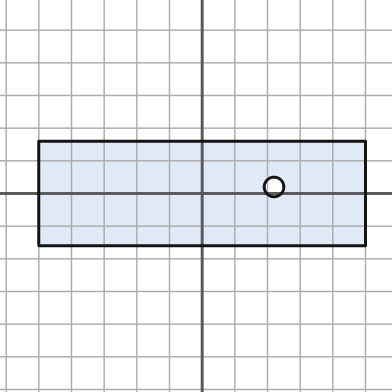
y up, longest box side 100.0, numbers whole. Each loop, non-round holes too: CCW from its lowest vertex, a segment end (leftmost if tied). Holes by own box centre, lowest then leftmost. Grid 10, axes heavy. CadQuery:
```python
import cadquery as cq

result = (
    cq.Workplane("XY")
    .moveTo(-50.0, -16.0)
    .lineTo(50.0, -16.0)
    .lineTo(50.0, 16.0)
    .lineTo(-50.0, 16.0)
    .close()
    .moveTo(22.0, 2.0)
    .circle(3.0)
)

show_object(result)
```